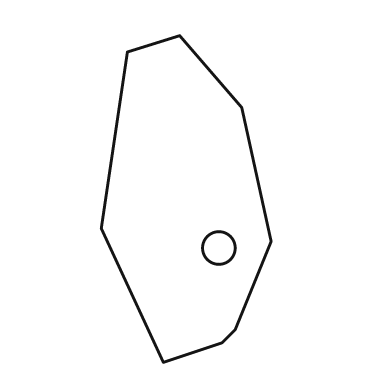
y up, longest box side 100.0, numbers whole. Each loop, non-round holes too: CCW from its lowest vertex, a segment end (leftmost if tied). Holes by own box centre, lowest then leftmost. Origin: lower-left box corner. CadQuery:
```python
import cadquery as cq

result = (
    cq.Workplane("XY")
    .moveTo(19.0, 0.0)
    .lineTo(37.0, 6.0)
    .lineTo(41.0, 10.0)
    .lineTo(52.0, 37.0)
    .lineTo(43.0, 78.0)
    .lineTo(24.0, 100.0)
    .lineTo(8.0, 95.0)
    .lineTo(0.0, 41.0)
    .close()
    .moveTo(36.0, 35.0)
    .circle(5.0)
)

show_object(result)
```